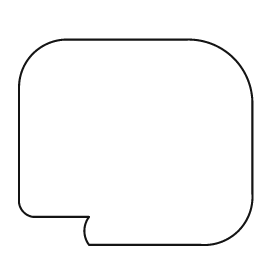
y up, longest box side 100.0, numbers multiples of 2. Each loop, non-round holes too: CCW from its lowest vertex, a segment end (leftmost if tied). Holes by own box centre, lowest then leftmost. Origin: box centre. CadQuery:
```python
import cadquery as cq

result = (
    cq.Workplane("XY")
    .moveTo(-20.0, -44.0)
    .lineTo(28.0, -44.0)
    .threePointArc((44.0, -38.0), (50.0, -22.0))
    .lineTo(50.0, 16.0)
    .threePointArc((42.0, 36.0), (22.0, 44.0))
    .lineTo(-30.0, 44.0)
    .threePointArc((-44.0, 38.0), (-50.0, 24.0))
    .lineTo(-50.0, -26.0)
    .threePointArc((-48.0, -30.0), (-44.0, -32.0))
    .lineTo(-20.0, -32.0)
    .threePointArc((-22.0, -38.0), (-20.0, -44.0))
    .close()
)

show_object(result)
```